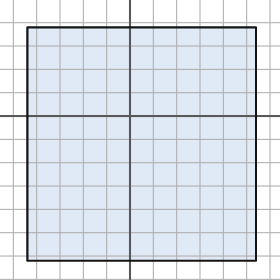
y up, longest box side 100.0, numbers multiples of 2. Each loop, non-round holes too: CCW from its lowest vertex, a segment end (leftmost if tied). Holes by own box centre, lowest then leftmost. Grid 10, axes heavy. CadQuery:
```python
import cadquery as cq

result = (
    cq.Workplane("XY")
    .moveTo(-44.0, -62.0)
    .lineTo(54.0, -62.0)
    .lineTo(54.0, 38.0)
    .lineTo(-44.0, 38.0)
    .close()
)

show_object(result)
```